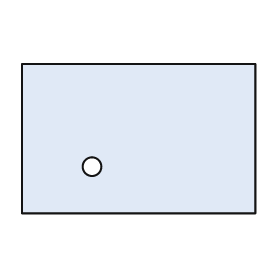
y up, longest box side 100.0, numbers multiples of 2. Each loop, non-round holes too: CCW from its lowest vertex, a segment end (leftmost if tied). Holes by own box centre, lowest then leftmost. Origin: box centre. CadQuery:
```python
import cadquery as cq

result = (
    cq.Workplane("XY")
    .moveTo(-50.0, -32.0)
    .lineTo(50.0, -32.0)
    .lineTo(50.0, 32.0)
    .lineTo(-50.0, 32.0)
    .close()
    .moveTo(-20.0, -12.0)
    .circle(4.0)
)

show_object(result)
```